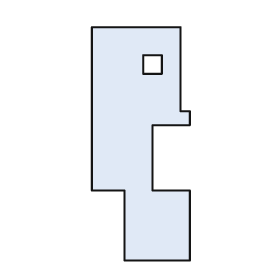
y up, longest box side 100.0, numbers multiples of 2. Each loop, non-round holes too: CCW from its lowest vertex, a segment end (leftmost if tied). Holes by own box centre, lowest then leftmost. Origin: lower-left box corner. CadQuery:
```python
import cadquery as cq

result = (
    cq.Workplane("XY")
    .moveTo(14.0, 0.0)
    .lineTo(42.0, 0.0)
    .lineTo(42.0, 30.0)
    .lineTo(26.0, 30.0)
    .lineTo(26.0, 58.0)
    .lineTo(42.0, 58.0)
    .lineTo(42.0, 64.0)
    .lineTo(38.0, 64.0)
    .lineTo(38.0, 100.0)
    .lineTo(0.0, 100.0)
    .lineTo(0.0, 30.0)
    .lineTo(14.0, 30.0)
    .close()
    .moveTo(22.0, 80.0)
    .lineTo(30.0, 80.0)
    .lineTo(30.0, 88.0)
    .lineTo(22.0, 88.0)
    .close()
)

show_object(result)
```